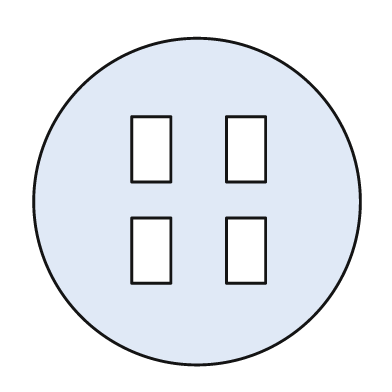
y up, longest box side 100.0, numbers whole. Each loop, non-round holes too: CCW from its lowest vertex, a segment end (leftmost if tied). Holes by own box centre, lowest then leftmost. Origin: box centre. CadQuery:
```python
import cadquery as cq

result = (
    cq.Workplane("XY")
    .moveTo(0.0, 0.0)
    .circle(50.0)
    .moveTo(-20.0, -25.0)
    .lineTo(-8.0, -25.0)
    .lineTo(-8.0, -5.0)
    .lineTo(-20.0, -5.0)
    .close()
    .moveTo(9.0, -25.0)
    .lineTo(21.0, -25.0)
    .lineTo(21.0, -5.0)
    .lineTo(9.0, -5.0)
    .close()
    .moveTo(-20.0, 6.0)
    .lineTo(-8.0, 6.0)
    .lineTo(-8.0, 26.0)
    .lineTo(-20.0, 26.0)
    .close()
    .moveTo(9.0, 6.0)
    .lineTo(21.0, 6.0)
    .lineTo(21.0, 26.0)
    .lineTo(9.0, 26.0)
    .close()
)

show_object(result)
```